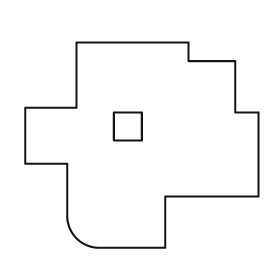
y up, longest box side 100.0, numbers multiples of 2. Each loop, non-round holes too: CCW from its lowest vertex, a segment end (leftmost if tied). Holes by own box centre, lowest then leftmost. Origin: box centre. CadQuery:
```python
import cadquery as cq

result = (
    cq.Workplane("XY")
    .moveTo(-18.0, -44.0)
    .lineTo(10.0, -44.0)
    .lineTo(10.0, -22.0)
    .lineTo(50.0, -22.0)
    .lineTo(50.0, 14.0)
    .lineTo(40.0, 14.0)
    .lineTo(40.0, 36.0)
    .lineTo(20.0, 36.0)
    .lineTo(20.0, 44.0)
    .lineTo(-28.0, 44.0)
    .lineTo(-28.0, 16.0)
    .lineTo(-50.0, 16.0)
    .lineTo(-50.0, -8.0)
    .lineTo(-32.0, -8.0)
    .lineTo(-32.0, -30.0)
    .threePointArc((-28.0, -40.0), (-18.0, -44.0))
    .close()
    .moveTo(-12.0, 2.0)
    .lineTo(0.0, 2.0)
    .lineTo(0.0, 14.0)
    .lineTo(-12.0, 14.0)
    .close()
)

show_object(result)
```